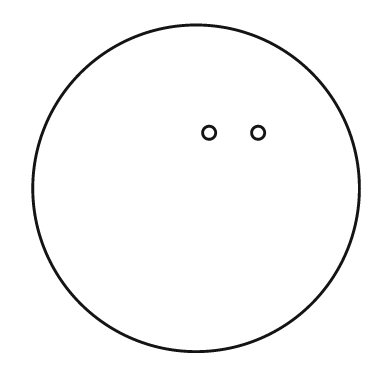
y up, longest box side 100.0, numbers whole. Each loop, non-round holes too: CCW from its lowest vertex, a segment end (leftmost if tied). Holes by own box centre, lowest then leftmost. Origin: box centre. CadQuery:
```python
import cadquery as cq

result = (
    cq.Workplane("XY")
    .moveTo(0.0, 0.0)
    .circle(50.0)
    .moveTo(4.0, 17.0)
    .circle(2.0)
    .moveTo(19.0, 17.0)
    .circle(2.0)
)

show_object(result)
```